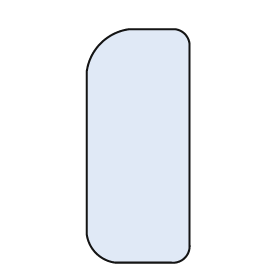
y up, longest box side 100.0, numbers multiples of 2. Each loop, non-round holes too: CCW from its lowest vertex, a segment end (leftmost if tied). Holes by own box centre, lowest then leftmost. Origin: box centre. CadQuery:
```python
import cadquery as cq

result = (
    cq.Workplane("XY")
    .moveTo(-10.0, -50.0)
    .lineTo(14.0, -50.0)
    .threePointArc((20.0, -48.0), (22.0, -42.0))
    .lineTo(22.0, 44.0)
    .threePointArc((20.0, 48.0), (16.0, 50.0))
    .lineTo(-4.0, 50.0)
    .threePointArc((-16.0, 44.0), (-22.0, 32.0))
    .lineTo(-22.0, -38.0)
    .threePointArc((-18.0, -46.0), (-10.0, -50.0))
    .close()
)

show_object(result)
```